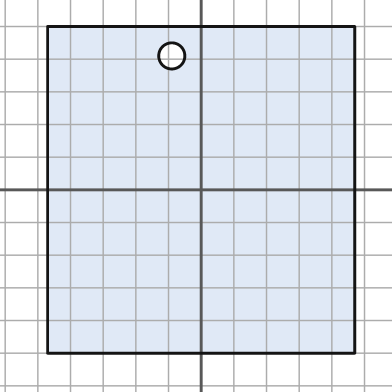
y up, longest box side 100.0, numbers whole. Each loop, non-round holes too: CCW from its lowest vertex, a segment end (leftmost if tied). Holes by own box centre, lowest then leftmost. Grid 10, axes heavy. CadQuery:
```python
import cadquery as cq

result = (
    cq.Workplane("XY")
    .moveTo(-47.0, -50.0)
    .lineTo(47.0, -50.0)
    .lineTo(47.0, 50.0)
    .lineTo(-47.0, 50.0)
    .close()
    .moveTo(-9.0, 41.0)
    .circle(4.0)
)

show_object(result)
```